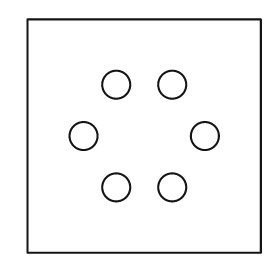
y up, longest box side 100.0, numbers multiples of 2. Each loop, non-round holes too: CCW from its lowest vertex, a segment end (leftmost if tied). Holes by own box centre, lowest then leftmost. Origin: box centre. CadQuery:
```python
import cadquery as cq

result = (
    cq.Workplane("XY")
    .moveTo(-50.0, -50.0)
    .lineTo(50.0, -50.0)
    .lineTo(50.0, 50.0)
    .lineTo(-50.0, 50.0)
    .close()
    .moveTo(-12.0, -22.0)
    .circle(6.0)
    .moveTo(12.0, -22.0)
    .circle(6.0)
    .moveTo(-26.0, 0.0)
    .circle(6.0)
    .moveTo(26.0, 0.0)
    .circle(6.0)
    .moveTo(-12.0, 22.0)
    .circle(6.0)
    .moveTo(12.0, 22.0)
    .circle(6.0)
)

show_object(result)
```